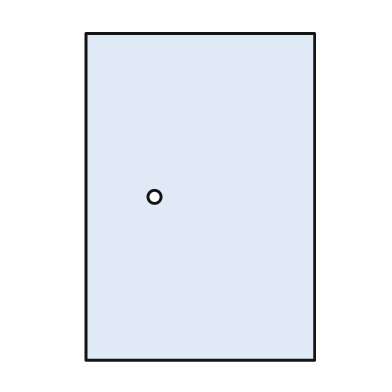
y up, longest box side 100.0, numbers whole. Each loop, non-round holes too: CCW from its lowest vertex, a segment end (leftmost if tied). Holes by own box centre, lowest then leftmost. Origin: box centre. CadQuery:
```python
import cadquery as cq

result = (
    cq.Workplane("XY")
    .moveTo(-35.0, -50.0)
    .lineTo(35.0, -50.0)
    .lineTo(35.0, 50.0)
    .lineTo(-35.0, 50.0)
    .close()
    .moveTo(-14.0, 0.0)
    .circle(2.0)
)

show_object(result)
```